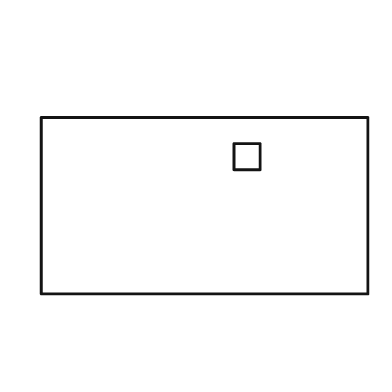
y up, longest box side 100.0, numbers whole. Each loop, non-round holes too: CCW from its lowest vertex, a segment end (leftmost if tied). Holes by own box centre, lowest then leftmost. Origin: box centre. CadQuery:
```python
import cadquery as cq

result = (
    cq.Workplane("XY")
    .moveTo(-50.0, -27.0)
    .lineTo(50.0, -27.0)
    .lineTo(50.0, 27.0)
    .lineTo(-50.0, 27.0)
    .close()
    .moveTo(9.0, 11.0)
    .lineTo(17.0, 11.0)
    .lineTo(17.0, 19.0)
    .lineTo(9.0, 19.0)
    .close()
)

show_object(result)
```